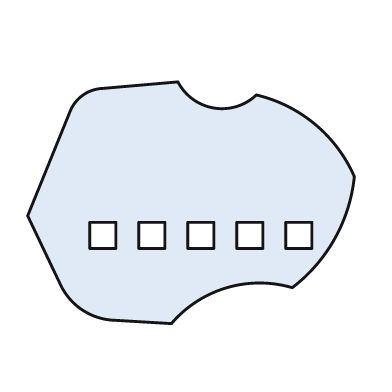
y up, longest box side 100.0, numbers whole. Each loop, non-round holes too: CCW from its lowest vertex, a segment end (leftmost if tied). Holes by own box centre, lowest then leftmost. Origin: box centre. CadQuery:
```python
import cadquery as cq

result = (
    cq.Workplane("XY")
    .moveTo(-6.0, -37.0)
    .threePointArc((11.0, -26.0), (31.0, -26.0))
    .threePointArc((44.0, -11.0), (50.0, 8.0))
    .threePointArc((38.0, 24.0), (20.0, 33.0))
    .threePointArc((7.0, 29.0), (-4.0, 37.0))
    .lineTo(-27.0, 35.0)
    .threePointArc((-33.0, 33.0), (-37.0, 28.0))
    .lineTo(-50.0, -4.0)
    .lineTo(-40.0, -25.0)
    .threePointArc((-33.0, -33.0), (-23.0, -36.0))
    .close()
    .moveTo(-31.0, -14.0)
    .lineTo(-23.0, -14.0)
    .lineTo(-23.0, -6.0)
    .lineTo(-31.0, -6.0)
    .close()
    .moveTo(-16.0, -14.0)
    .lineTo(-8.0, -14.0)
    .lineTo(-8.0, -6.0)
    .lineTo(-16.0, -6.0)
    .close()
    .moveTo(-1.0, -14.0)
    .lineTo(7.0, -14.0)
    .lineTo(7.0, -6.0)
    .lineTo(-1.0, -6.0)
    .close()
    .moveTo(14.0, -14.0)
    .lineTo(22.0, -14.0)
    .lineTo(22.0, -6.0)
    .lineTo(14.0, -6.0)
    .close()
    .moveTo(29.0, -14.0)
    .lineTo(37.0, -14.0)
    .lineTo(37.0, -6.0)
    .lineTo(29.0, -6.0)
    .close()
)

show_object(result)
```